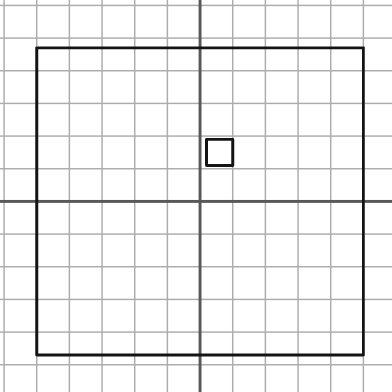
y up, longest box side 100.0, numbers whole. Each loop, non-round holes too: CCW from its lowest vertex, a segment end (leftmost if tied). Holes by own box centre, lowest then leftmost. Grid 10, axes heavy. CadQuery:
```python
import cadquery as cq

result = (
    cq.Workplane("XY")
    .moveTo(-50.0, -47.0)
    .lineTo(50.0, -47.0)
    .lineTo(50.0, 47.0)
    .lineTo(-50.0, 47.0)
    .close()
    .moveTo(2.0, 11.0)
    .lineTo(10.0, 11.0)
    .lineTo(10.0, 19.0)
    .lineTo(2.0, 19.0)
    .close()
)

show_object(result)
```